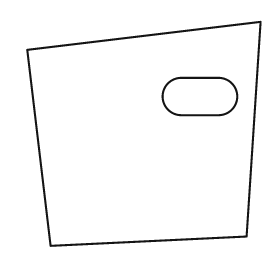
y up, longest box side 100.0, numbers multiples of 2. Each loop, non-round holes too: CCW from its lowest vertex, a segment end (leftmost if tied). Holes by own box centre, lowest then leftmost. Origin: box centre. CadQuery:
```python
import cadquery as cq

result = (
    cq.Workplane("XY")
    .moveTo(-40.0, -48.0)
    .lineTo(44.0, -44.0)
    .lineTo(50.0, 48.0)
    .lineTo(-50.0, 36.0)
    .close()
    .moveTo(16.0, 8.0)
    .lineTo(32.0, 8.0)
    .threePointArc((40.0, 16.0), (32.0, 24.0))
    .lineTo(16.0, 24.0)
    .threePointArc((8.0, 16.0), (16.0, 8.0))
    .close()
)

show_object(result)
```